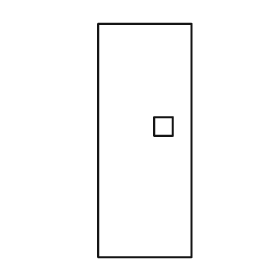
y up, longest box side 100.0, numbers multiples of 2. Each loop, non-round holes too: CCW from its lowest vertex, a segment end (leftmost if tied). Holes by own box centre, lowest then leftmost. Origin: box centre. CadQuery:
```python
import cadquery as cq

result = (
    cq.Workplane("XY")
    .moveTo(-20.0, -50.0)
    .lineTo(20.0, -50.0)
    .lineTo(20.0, 50.0)
    .lineTo(-20.0, 50.0)
    .close()
    .moveTo(4.0, 2.0)
    .lineTo(12.0, 2.0)
    .lineTo(12.0, 10.0)
    .lineTo(4.0, 10.0)
    .close()
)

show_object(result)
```